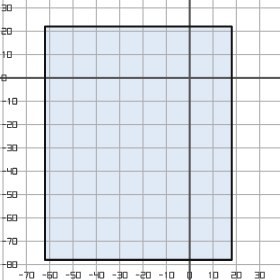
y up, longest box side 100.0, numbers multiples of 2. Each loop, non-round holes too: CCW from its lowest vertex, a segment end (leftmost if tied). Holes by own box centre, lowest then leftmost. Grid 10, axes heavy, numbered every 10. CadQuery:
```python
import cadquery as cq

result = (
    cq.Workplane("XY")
    .moveTo(-62.0, -78.0)
    .lineTo(18.0, -78.0)
    .lineTo(18.0, 22.0)
    .lineTo(-62.0, 22.0)
    .close()
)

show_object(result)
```